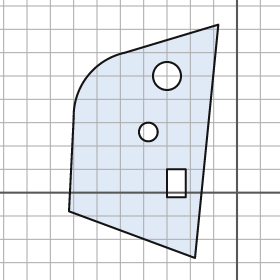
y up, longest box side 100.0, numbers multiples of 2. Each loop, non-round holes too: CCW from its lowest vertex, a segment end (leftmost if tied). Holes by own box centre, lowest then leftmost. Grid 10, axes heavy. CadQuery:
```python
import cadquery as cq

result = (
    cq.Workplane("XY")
    .moveTo(-18.0, -28.0)
    .lineTo(-8.0, 72.0)
    .lineTo(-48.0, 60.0)
    .threePointArc((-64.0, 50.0), (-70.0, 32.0))
    .lineTo(-72.0, -8.0)
    .close()
    .moveTo(-30.0, -2.0)
    .lineTo(-22.0, -2.0)
    .lineTo(-22.0, 10.0)
    .lineTo(-30.0, 10.0)
    .close()
    .moveTo(-38.0, 26.0)
    .circle(4.0)
    .moveTo(-30.0, 50.0)
    .circle(6.0)
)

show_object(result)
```